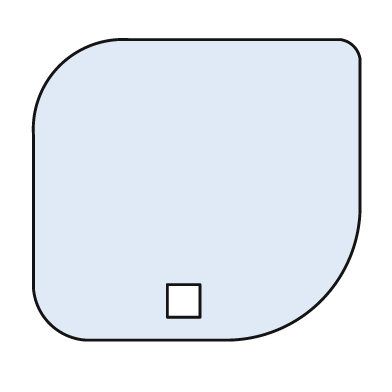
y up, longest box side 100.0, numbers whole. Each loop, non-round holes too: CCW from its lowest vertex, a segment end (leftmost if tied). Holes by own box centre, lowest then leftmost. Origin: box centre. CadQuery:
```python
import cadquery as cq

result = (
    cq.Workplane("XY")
    .moveTo(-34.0, -46.0)
    .lineTo(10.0, -46.0)
    .threePointArc((38.0, -34.0), (50.0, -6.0))
    .lineTo(50.0, 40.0)
    .threePointArc((48.0, 44.0), (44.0, 46.0))
    .lineTo(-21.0, 46.0)
    .threePointArc((-42.0, 38.0), (-50.0, 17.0))
    .lineTo(-50.0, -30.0)
    .threePointArc((-45.0, -41.0), (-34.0, -46.0))
    .close()
    .moveTo(-9.0, -39.0)
    .lineTo(1.0, -39.0)
    .lineTo(1.0, -29.0)
    .lineTo(-9.0, -29.0)
    .close()
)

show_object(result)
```